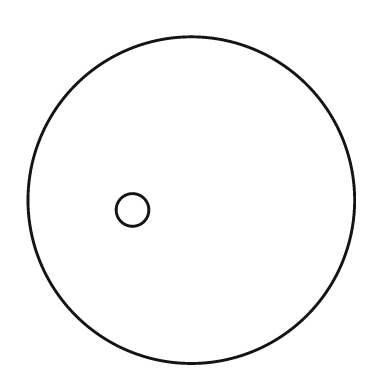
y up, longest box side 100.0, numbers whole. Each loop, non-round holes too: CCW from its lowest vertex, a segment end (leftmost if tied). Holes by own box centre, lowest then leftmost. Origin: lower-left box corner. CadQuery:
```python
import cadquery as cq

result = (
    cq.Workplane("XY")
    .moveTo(50.0, 50.0)
    .circle(50.0)
    .moveTo(32.0, 47.0)
    .circle(5.0)
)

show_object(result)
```